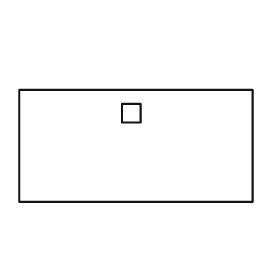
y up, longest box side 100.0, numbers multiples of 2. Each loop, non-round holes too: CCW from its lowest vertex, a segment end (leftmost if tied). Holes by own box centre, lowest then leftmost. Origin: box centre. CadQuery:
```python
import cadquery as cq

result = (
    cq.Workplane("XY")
    .moveTo(-50.0, -24.0)
    .lineTo(50.0, -24.0)
    .lineTo(50.0, 24.0)
    .lineTo(-50.0, 24.0)
    .close()
    .moveTo(-6.0, 10.0)
    .lineTo(2.0, 10.0)
    .lineTo(2.0, 18.0)
    .lineTo(-6.0, 18.0)
    .close()
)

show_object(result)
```